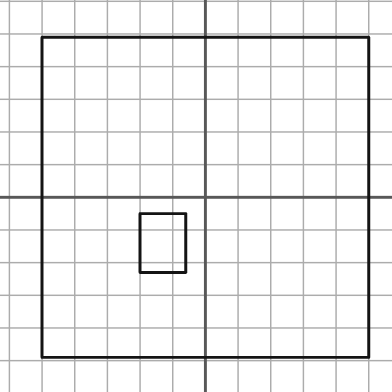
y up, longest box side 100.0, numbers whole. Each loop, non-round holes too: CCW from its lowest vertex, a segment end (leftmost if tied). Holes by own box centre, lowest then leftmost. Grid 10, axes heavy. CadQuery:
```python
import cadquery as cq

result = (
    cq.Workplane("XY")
    .moveTo(-50.0, -49.0)
    .lineTo(50.0, -49.0)
    .lineTo(50.0, 49.0)
    .lineTo(-50.0, 49.0)
    .close()
    .moveTo(-20.0, -23.0)
    .lineTo(-6.0, -23.0)
    .lineTo(-6.0, -5.0)
    .lineTo(-20.0, -5.0)
    .close()
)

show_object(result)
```